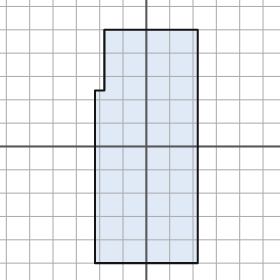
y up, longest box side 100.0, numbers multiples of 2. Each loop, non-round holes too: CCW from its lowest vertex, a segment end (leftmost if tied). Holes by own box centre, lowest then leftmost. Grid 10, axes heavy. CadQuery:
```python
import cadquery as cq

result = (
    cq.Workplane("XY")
    .moveTo(-22.0, -50.0)
    .lineTo(22.0, -50.0)
    .lineTo(22.0, 50.0)
    .lineTo(-18.0, 50.0)
    .lineTo(-18.0, 24.0)
    .lineTo(-22.0, 24.0)
    .close()
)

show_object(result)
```